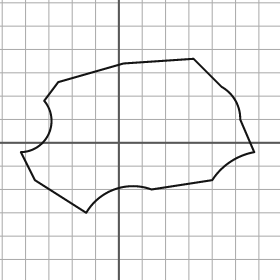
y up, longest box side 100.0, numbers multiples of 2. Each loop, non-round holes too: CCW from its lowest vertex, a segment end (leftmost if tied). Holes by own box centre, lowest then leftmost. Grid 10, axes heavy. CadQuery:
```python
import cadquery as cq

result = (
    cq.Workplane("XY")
    .moveTo(-14.0, -30.0)
    .threePointArc((-2.0, -20.0), (14.0, -20.0))
    .lineTo(40.0, -16.0)
    .threePointArc((48.0, -8.0), (58.0, -4.0))
    .lineTo(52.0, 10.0)
    .threePointArc((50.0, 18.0), (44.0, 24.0))
    .lineTo(32.0, 36.0)
    .lineTo(2.0, 34.0)
    .lineTo(-26.0, 26.0)
    .lineTo(-32.0, 18.0)
    .threePointArc((-30.0, 4.0), (-42.0, -4.0))
    .lineTo(-36.0, -16.0)
    .close()
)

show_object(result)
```